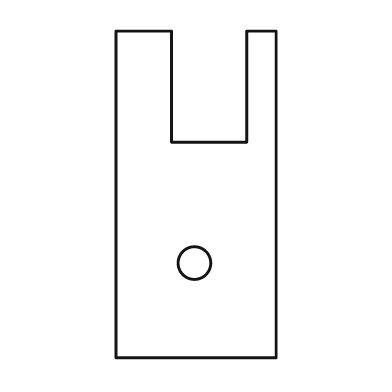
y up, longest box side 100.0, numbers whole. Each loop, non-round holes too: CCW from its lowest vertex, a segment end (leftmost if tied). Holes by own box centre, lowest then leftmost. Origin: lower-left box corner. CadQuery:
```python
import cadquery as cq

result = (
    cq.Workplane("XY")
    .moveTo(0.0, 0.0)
    .lineTo(49.0, 0.0)
    .lineTo(49.0, 100.0)
    .lineTo(40.0, 100.0)
    .lineTo(40.0, 66.0)
    .lineTo(17.0, 66.0)
    .lineTo(17.0, 100.0)
    .lineTo(0.0, 100.0)
    .close()
    .moveTo(24.0, 29.0)
    .circle(5.0)
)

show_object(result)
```